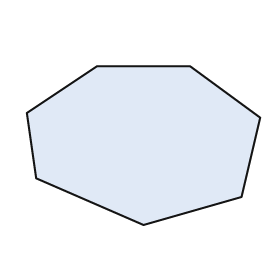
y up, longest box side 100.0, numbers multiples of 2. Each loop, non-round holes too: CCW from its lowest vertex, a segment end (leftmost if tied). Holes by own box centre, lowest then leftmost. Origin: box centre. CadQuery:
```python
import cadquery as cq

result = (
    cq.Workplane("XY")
    .moveTo(0.0, -34.0)
    .lineTo(42.0, -22.0)
    .lineTo(50.0, 12.0)
    .lineTo(20.0, 34.0)
    .lineTo(-20.0, 34.0)
    .lineTo(-50.0, 14.0)
    .lineTo(-46.0, -14.0)
    .close()
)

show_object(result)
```